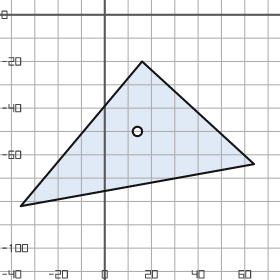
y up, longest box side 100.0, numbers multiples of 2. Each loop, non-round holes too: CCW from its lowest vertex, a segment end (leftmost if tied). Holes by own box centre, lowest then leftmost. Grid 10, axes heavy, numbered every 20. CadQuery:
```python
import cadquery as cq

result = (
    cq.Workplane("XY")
    .moveTo(-36.0, -82.0)
    .lineTo(64.0, -64.0)
    .lineTo(16.0, -20.0)
    .close()
    .moveTo(14.0, -50.0)
    .circle(2.0)
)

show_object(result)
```